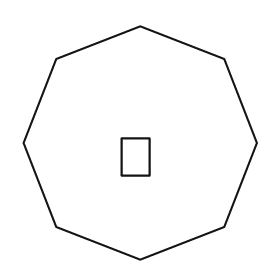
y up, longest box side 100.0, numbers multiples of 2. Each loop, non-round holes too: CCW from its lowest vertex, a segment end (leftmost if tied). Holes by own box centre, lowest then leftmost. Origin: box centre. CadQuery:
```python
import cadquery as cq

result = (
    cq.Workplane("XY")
    .moveTo(0.0, -50.0)
    .lineTo(36.0, -36.0)
    .lineTo(50.0, 0.0)
    .lineTo(36.0, 36.0)
    .lineTo(0.0, 50.0)
    .lineTo(-36.0, 36.0)
    .lineTo(-50.0, 0.0)
    .lineTo(-36.0, -36.0)
    .close()
    .moveTo(-8.0, -14.0)
    .lineTo(4.0, -14.0)
    .lineTo(4.0, 2.0)
    .lineTo(-8.0, 2.0)
    .close()
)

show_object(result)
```